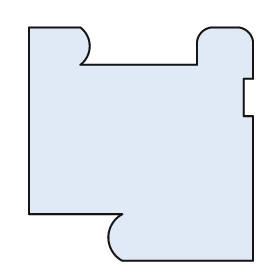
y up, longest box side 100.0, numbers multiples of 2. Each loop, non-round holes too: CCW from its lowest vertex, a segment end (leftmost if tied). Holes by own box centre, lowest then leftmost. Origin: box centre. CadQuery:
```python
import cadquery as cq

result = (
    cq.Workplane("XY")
    .moveTo(-8.0, -50.0)
    .lineTo(48.0, -50.0)
    .lineTo(48.0, 12.0)
    .lineTo(44.0, 12.0)
    .lineTo(44.0, 28.0)
    .lineTo(48.0, 28.0)
    .lineTo(48.0, 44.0)
    .threePointArc((46.0, 48.0), (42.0, 50.0))
    .lineTo(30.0, 50.0)
    .threePointArc((26.0, 48.0), (24.0, 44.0))
    .lineTo(24.0, 34.0)
    .lineTo(-26.0, 34.0)
    .threePointArc((-22.0, 42.0), (-26.0, 50.0))
    .lineTo(-48.0, 50.0)
    .lineTo(-48.0, -30.0)
    .lineTo(-8.0, -30.0)
    .threePointArc((-14.0, -40.0), (-8.0, -50.0))
    .close()
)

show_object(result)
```